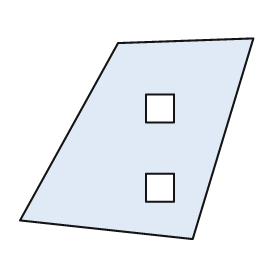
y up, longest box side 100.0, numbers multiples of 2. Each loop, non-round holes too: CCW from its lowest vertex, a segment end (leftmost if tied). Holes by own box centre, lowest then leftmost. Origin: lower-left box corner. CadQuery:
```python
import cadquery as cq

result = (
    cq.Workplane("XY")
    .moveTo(74.0, 0.0)
    .lineTo(100.0, 86.0)
    .lineTo(42.0, 84.0)
    .lineTo(0.0, 8.0)
    .close()
    .moveTo(54.0, 16.0)
    .lineTo(66.0, 16.0)
    .lineTo(66.0, 28.0)
    .lineTo(54.0, 28.0)
    .close()
    .moveTo(54.0, 50.0)
    .lineTo(66.0, 50.0)
    .lineTo(66.0, 62.0)
    .lineTo(54.0, 62.0)
    .close()
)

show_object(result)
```